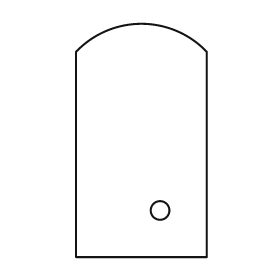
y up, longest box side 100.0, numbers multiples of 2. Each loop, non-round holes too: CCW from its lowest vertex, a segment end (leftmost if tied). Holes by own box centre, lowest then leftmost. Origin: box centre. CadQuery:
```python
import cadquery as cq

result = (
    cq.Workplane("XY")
    .moveTo(-28.0, -50.0)
    .lineTo(28.0, -50.0)
    .lineTo(28.0, 38.0)
    .threePointArc((0.0, 50.0), (-28.0, 38.0))
    .close()
    .moveTo(8.0, -30.0)
    .circle(4.0)
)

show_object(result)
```